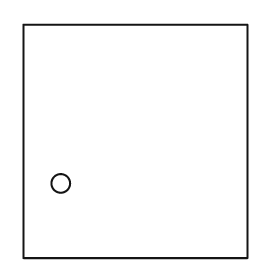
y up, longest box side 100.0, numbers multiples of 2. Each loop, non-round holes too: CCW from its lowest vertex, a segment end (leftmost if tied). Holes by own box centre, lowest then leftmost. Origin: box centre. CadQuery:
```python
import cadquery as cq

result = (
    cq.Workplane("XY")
    .moveTo(-48.0, -50.0)
    .lineTo(48.0, -50.0)
    .lineTo(48.0, 50.0)
    .lineTo(-48.0, 50.0)
    .close()
    .moveTo(-32.0, -18.0)
    .circle(4.0)
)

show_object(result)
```